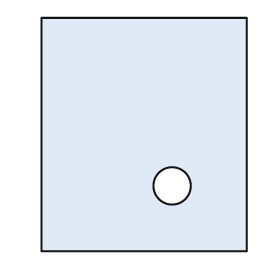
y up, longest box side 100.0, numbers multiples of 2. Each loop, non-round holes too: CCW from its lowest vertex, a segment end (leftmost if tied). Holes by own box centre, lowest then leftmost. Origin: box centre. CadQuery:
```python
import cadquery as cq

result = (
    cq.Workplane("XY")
    .moveTo(-44.0, -50.0)
    .lineTo(44.0, -50.0)
    .lineTo(44.0, 50.0)
    .lineTo(-44.0, 50.0)
    .close()
    .moveTo(12.0, -22.0)
    .circle(8.0)
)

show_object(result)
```